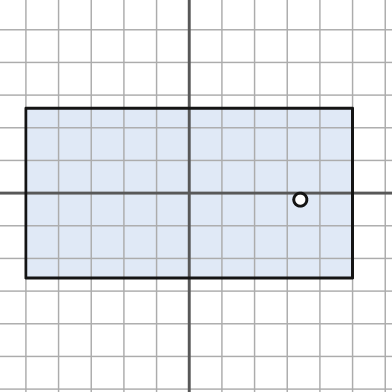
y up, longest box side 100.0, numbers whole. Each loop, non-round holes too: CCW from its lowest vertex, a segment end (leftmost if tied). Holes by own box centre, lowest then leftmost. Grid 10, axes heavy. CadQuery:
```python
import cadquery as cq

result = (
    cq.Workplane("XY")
    .moveTo(-50.0, -26.0)
    .lineTo(50.0, -26.0)
    .lineTo(50.0, 26.0)
    .lineTo(-50.0, 26.0)
    .close()
    .moveTo(34.0, -2.0)
    .circle(2.0)
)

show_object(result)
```